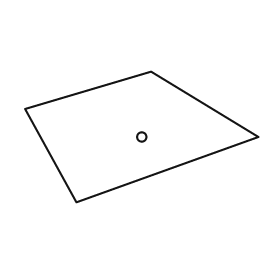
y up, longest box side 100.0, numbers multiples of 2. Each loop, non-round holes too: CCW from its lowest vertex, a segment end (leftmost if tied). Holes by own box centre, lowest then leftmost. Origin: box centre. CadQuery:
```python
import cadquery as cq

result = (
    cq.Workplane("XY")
    .moveTo(-28.0, -28.0)
    .lineTo(50.0, 0.0)
    .lineTo(4.0, 28.0)
    .lineTo(-50.0, 12.0)
    .close()
    .moveTo(0.0, 0.0)
    .circle(2.0)
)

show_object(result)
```